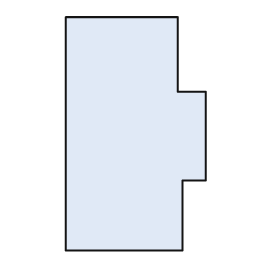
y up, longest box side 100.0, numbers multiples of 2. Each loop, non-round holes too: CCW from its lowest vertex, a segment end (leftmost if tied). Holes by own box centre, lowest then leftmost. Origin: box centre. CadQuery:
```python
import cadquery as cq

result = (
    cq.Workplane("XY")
    .moveTo(-30.0, -50.0)
    .lineTo(20.0, -50.0)
    .lineTo(20.0, -20.0)
    .lineTo(30.0, -20.0)
    .lineTo(30.0, 18.0)
    .lineTo(18.0, 18.0)
    .lineTo(18.0, 50.0)
    .lineTo(-30.0, 50.0)
    .close()
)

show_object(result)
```